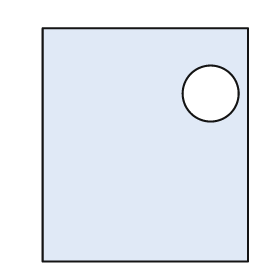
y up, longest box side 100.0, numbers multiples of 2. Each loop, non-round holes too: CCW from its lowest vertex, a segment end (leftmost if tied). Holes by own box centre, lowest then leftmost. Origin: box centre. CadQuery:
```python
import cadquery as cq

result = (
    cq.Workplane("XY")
    .moveTo(-44.0, -50.0)
    .lineTo(44.0, -50.0)
    .lineTo(44.0, 50.0)
    .lineTo(-44.0, 50.0)
    .close()
    .moveTo(28.0, 22.0)
    .circle(12.0)
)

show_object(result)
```